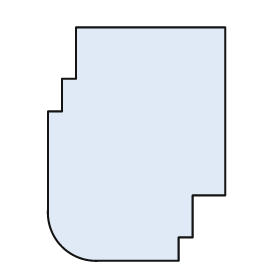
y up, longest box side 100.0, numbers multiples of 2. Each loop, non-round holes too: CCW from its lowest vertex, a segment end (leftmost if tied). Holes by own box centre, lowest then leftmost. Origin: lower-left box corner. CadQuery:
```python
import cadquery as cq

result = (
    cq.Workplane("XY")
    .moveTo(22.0, 0.0)
    .lineTo(56.0, 0.0)
    .lineTo(56.0, 10.0)
    .lineTo(62.0, 10.0)
    .lineTo(62.0, 28.0)
    .lineTo(76.0, 28.0)
    .lineTo(76.0, 100.0)
    .lineTo(12.0, 100.0)
    .lineTo(12.0, 78.0)
    .lineTo(6.0, 78.0)
    .lineTo(6.0, 64.0)
    .lineTo(0.0, 64.0)
    .lineTo(0.0, 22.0)
    .threePointArc((6.0, 6.0), (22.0, 0.0))
    .close()
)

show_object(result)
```